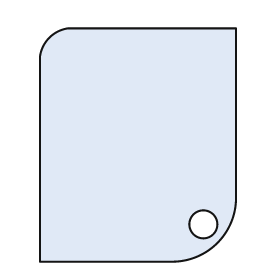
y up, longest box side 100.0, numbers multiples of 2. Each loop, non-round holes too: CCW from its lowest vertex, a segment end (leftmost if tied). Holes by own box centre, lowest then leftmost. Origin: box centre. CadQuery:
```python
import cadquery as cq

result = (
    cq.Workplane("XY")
    .moveTo(-42.0, -50.0)
    .lineTo(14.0, -50.0)
    .threePointArc((34.0, -42.0), (42.0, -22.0))
    .lineTo(42.0, 50.0)
    .lineTo(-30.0, 50.0)
    .threePointArc((-38.0, 46.0), (-42.0, 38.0))
    .close()
    .moveTo(28.0, -34.0)
    .circle(6.0)
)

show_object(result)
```